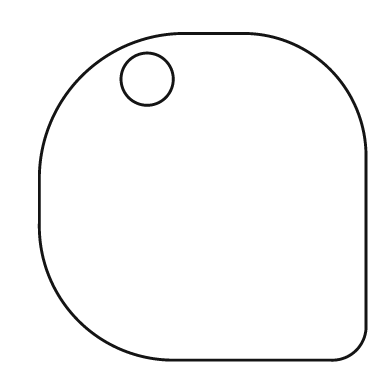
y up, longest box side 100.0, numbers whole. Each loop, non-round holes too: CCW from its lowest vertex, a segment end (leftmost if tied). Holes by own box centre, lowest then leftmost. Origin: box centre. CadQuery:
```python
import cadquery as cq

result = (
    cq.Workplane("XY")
    .moveTo(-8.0, -50.0)
    .lineTo(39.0, -50.0)
    .threePointArc((47.0, -47.0), (50.0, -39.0))
    .lineTo(50.0, 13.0)
    .threePointArc((39.0, 39.0), (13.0, 50.0))
    .lineTo(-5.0, 50.0)
    .threePointArc((-37.0, 37.0), (-50.0, 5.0))
    .lineTo(-50.0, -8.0)
    .threePointArc((-38.0, -38.0), (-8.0, -50.0))
    .close()
    .moveTo(-17.0, 36.0)
    .circle(8.0)
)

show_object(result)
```